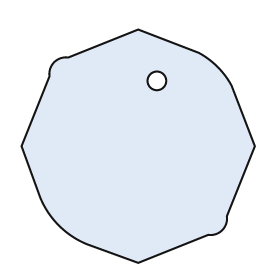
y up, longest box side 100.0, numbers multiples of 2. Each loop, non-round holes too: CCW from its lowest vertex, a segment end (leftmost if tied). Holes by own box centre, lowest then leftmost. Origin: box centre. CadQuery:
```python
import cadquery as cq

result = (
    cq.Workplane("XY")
    .moveTo(0.0, -50.0)
    .lineTo(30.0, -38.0)
    .threePointArc((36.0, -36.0), (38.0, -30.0))
    .lineTo(50.0, 0.0)
    .lineTo(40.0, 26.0)
    .threePointArc((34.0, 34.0), (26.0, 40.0))
    .lineTo(0.0, 50.0)
    .lineTo(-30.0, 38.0)
    .threePointArc((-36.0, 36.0), (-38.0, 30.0))
    .lineTo(-50.0, 0.0)
    .lineTo(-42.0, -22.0)
    .threePointArc((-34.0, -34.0), (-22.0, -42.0))
    .close()
    .moveTo(8.0, 28.0)
    .circle(4.0)
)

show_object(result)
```